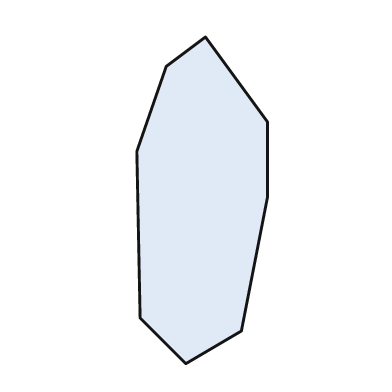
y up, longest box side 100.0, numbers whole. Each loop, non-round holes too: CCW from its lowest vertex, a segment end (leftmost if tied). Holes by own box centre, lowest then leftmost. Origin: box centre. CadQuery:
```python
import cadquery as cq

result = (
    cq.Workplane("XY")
    .moveTo(-5.0, -50.0)
    .lineTo(12.0, -40.0)
    .lineTo(20.0, 1.0)
    .lineTo(20.0, 24.0)
    .lineTo(1.0, 50.0)
    .lineTo(-11.0, 41.0)
    .lineTo(-20.0, 15.0)
    .lineTo(-19.0, -36.0)
    .close()
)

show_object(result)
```